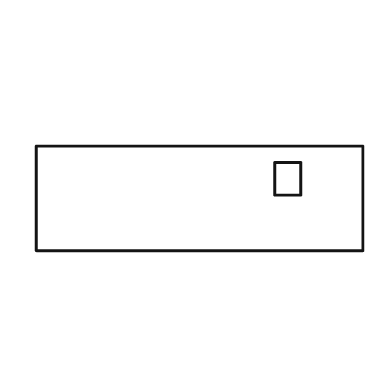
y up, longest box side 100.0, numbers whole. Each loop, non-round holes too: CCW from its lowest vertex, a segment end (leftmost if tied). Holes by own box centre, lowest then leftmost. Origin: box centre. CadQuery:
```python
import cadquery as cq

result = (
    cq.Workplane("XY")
    .moveTo(-50.0, -16.0)
    .lineTo(50.0, -16.0)
    .lineTo(50.0, 16.0)
    .lineTo(-50.0, 16.0)
    .close()
    .moveTo(23.0, 1.0)
    .lineTo(31.0, 1.0)
    .lineTo(31.0, 11.0)
    .lineTo(23.0, 11.0)
    .close()
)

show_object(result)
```